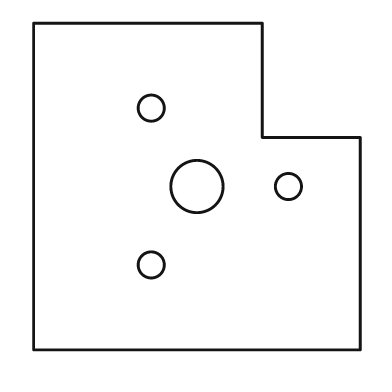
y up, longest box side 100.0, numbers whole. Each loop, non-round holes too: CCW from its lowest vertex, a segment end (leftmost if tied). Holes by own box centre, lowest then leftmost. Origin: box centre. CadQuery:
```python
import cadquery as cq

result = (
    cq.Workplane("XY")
    .moveTo(-50.0, -50.0)
    .lineTo(50.0, -50.0)
    .lineTo(50.0, 15.0)
    .lineTo(20.0, 15.0)
    .lineTo(20.0, 50.0)
    .lineTo(-50.0, 50.0)
    .close()
    .moveTo(-14.0, -24.0)
    .circle(4.0)
    .moveTo(0.0, 0.0)
    .circle(8.0)
    .moveTo(28.0, 0.0)
    .circle(4.0)
    .moveTo(-14.0, 24.0)
    .circle(4.0)
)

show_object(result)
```